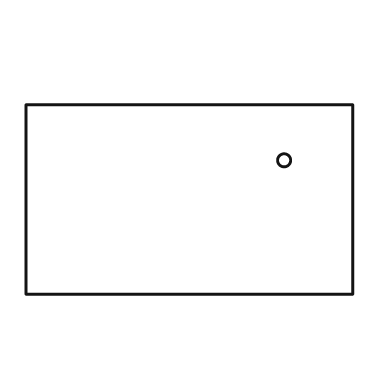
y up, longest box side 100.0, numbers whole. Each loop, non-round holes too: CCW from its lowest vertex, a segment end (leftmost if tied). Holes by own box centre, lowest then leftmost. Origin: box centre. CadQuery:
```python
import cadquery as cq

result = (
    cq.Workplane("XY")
    .moveTo(-50.0, -29.0)
    .lineTo(50.0, -29.0)
    .lineTo(50.0, 29.0)
    .lineTo(-50.0, 29.0)
    .close()
    .moveTo(29.0, 12.0)
    .circle(2.0)
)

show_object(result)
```